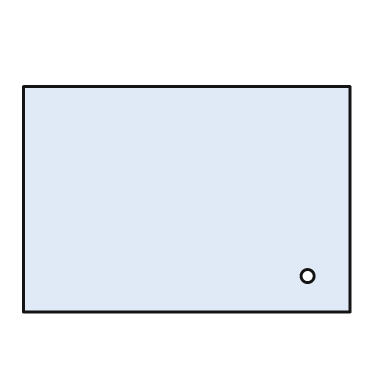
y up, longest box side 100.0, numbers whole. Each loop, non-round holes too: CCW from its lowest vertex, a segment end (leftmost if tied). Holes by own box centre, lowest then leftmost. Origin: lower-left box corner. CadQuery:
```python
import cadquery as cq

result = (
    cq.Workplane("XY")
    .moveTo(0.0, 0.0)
    .lineTo(100.0, 0.0)
    .lineTo(100.0, 69.0)
    .lineTo(0.0, 69.0)
    .close()
    .moveTo(87.0, 11.0)
    .circle(2.0)
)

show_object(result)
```